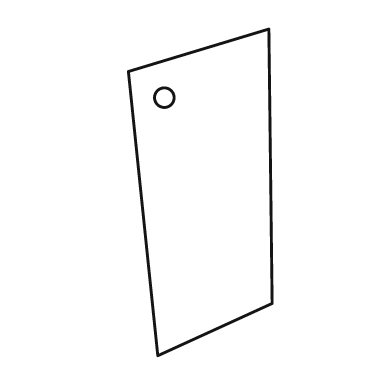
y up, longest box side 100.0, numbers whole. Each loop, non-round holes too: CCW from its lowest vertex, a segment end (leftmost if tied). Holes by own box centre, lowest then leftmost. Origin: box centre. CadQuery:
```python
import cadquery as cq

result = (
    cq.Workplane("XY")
    .moveTo(-13.0, -50.0)
    .lineTo(22.0, -34.0)
    .lineTo(21.0, 50.0)
    .lineTo(-22.0, 37.0)
    .close()
    .moveTo(-11.0, 29.0)
    .circle(3.0)
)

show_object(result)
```